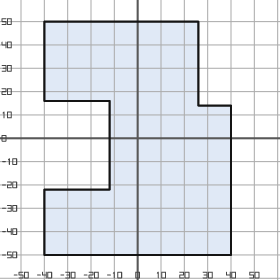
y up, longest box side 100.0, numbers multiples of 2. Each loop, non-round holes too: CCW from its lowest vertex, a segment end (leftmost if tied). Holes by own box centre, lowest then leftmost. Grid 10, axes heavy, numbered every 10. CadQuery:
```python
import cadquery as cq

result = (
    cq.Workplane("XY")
    .moveTo(-40.0, -50.0)
    .lineTo(40.0, -50.0)
    .lineTo(40.0, 14.0)
    .lineTo(26.0, 14.0)
    .lineTo(26.0, 50.0)
    .lineTo(-40.0, 50.0)
    .lineTo(-40.0, 16.0)
    .lineTo(-12.0, 16.0)
    .lineTo(-12.0, -22.0)
    .lineTo(-40.0, -22.0)
    .close()
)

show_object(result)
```